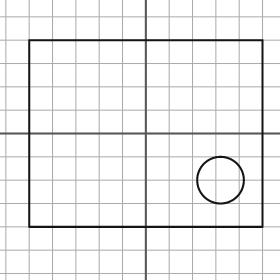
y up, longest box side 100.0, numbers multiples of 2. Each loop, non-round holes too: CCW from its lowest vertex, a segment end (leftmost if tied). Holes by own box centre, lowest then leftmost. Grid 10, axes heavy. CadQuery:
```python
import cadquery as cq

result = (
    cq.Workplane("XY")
    .moveTo(-50.0, -40.0)
    .lineTo(50.0, -40.0)
    .lineTo(50.0, 40.0)
    .lineTo(-50.0, 40.0)
    .close()
    .moveTo(32.0, -20.0)
    .circle(10.0)
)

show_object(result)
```